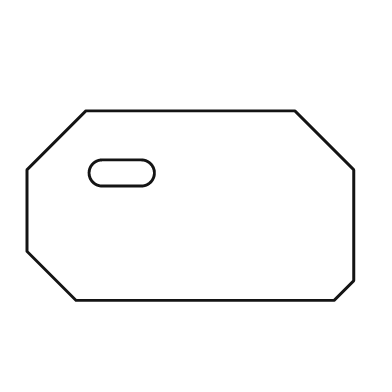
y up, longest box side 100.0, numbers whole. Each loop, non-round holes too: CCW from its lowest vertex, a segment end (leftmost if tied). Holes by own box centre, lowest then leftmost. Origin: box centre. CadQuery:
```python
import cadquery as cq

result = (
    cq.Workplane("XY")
    .moveTo(-35.0, -29.0)
    .lineTo(44.0, -29.0)
    .lineTo(50.0, -23.0)
    .lineTo(50.0, 11.0)
    .lineTo(32.0, 29.0)
    .lineTo(-32.0, 29.0)
    .lineTo(-50.0, 11.0)
    .lineTo(-50.0, -14.0)
    .close()
    .moveTo(-27.0, 6.0)
    .lineTo(-15.0, 6.0)
    .threePointArc((-11.0, 10.0), (-15.0, 14.0))
    .lineTo(-27.0, 14.0)
    .threePointArc((-31.0, 10.0), (-27.0, 6.0))
    .close()
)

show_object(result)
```